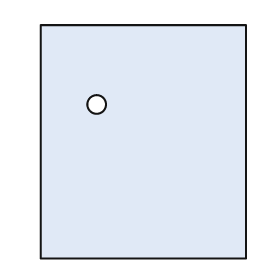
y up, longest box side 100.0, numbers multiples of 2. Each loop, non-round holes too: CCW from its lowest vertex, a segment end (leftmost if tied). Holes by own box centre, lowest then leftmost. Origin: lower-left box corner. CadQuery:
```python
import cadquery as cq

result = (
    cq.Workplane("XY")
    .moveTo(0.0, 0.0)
    .lineTo(88.0, 0.0)
    .lineTo(88.0, 100.0)
    .lineTo(0.0, 100.0)
    .close()
    .moveTo(24.0, 66.0)
    .circle(4.0)
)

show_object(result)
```